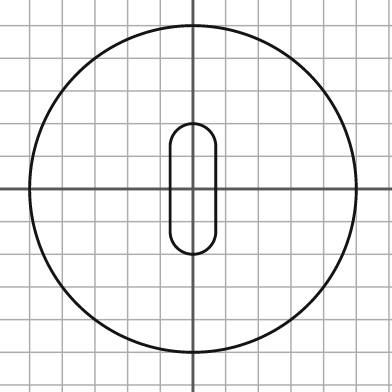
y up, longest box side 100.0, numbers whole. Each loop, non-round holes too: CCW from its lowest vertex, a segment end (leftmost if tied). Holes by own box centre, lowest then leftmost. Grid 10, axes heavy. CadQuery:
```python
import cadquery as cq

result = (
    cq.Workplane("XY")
    .moveTo(0.0, 0.0)
    .circle(50.0)
    .moveTo(-7.0, -13.0)
    .threePointArc((0.0, -20.0), (7.0, -13.0))
    .lineTo(7.0, 13.0)
    .threePointArc((0.0, 20.0), (-7.0, 13.0))
    .close()
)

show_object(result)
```